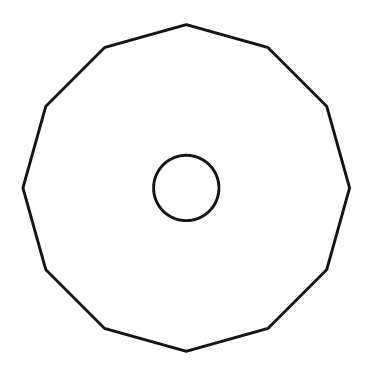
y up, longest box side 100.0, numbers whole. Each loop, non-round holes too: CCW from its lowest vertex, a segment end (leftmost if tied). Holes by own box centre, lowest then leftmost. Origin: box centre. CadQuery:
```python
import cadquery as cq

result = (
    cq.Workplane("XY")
    .moveTo(0.0, -50.0)
    .lineTo(25.0, -43.0)
    .lineTo(43.0, -25.0)
    .lineTo(50.0, 0.0)
    .lineTo(43.0, 25.0)
    .lineTo(25.0, 43.0)
    .lineTo(0.0, 50.0)
    .lineTo(-25.0, 43.0)
    .lineTo(-43.0, 25.0)
    .lineTo(-50.0, 0.0)
    .lineTo(-43.0, -25.0)
    .lineTo(-25.0, -43.0)
    .close()
    .moveTo(0.0, 0.0)
    .circle(10.0)
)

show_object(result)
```